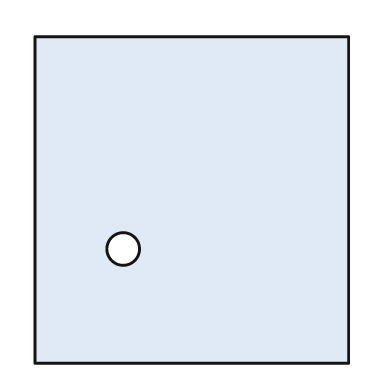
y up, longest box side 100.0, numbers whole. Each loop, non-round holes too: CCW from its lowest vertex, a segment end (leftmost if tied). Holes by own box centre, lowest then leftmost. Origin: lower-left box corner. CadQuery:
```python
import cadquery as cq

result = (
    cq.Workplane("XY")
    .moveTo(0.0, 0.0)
    .lineTo(96.0, 0.0)
    .lineTo(96.0, 100.0)
    .lineTo(0.0, 100.0)
    .close()
    .moveTo(27.0, 35.0)
    .circle(5.0)
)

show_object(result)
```